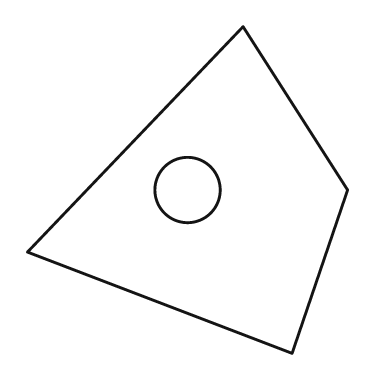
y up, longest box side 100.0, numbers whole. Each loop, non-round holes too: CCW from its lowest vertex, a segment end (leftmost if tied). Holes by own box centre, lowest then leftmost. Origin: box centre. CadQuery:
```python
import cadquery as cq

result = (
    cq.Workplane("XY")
    .moveTo(32.0, -50.0)
    .lineTo(49.0, 0.0)
    .lineTo(17.0, 50.0)
    .lineTo(-49.0, -19.0)
    .close()
    .moveTo(0.0, 0.0)
    .circle(10.0)
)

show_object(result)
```